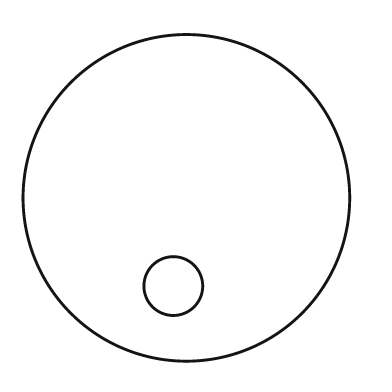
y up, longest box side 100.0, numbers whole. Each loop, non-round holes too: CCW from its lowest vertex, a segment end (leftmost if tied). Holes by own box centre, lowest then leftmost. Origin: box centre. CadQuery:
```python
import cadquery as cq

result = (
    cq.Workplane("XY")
    .moveTo(0.0, 0.0)
    .circle(50.0)
    .moveTo(-4.0, -27.0)
    .circle(9.0)
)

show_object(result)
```